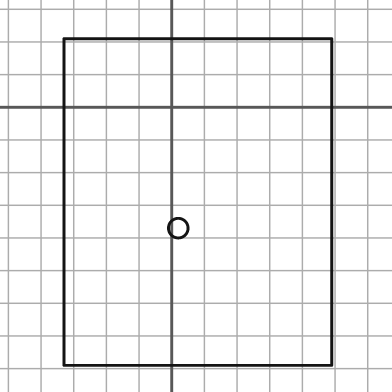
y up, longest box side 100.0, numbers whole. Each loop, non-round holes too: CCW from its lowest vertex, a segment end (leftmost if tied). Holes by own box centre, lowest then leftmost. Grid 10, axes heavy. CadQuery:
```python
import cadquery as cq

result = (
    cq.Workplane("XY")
    .moveTo(-33.0, -79.0)
    .lineTo(49.0, -79.0)
    .lineTo(49.0, 21.0)
    .lineTo(-33.0, 21.0)
    .close()
    .moveTo(2.0, -37.0)
    .circle(3.0)
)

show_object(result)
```